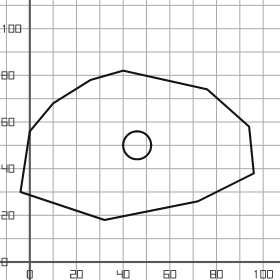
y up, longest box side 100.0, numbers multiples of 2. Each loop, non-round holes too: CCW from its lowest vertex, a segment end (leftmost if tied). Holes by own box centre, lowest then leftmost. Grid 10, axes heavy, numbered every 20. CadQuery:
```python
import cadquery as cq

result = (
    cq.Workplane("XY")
    .moveTo(32.0, 18.0)
    .lineTo(72.0, 26.0)
    .lineTo(96.0, 38.0)
    .lineTo(94.0, 58.0)
    .lineTo(76.0, 74.0)
    .lineTo(40.0, 82.0)
    .lineTo(26.0, 78.0)
    .lineTo(10.0, 68.0)
    .lineTo(0.0, 56.0)
    .lineTo(-4.0, 30.0)
    .close()
    .moveTo(46.0, 50.0)
    .circle(6.0)
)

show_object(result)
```